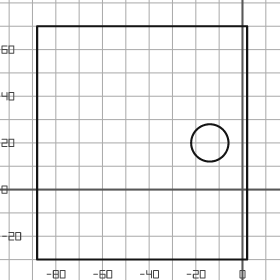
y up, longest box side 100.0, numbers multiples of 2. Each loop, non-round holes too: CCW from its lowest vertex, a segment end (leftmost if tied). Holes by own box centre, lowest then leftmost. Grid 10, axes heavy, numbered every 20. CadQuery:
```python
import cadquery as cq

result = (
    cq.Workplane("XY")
    .moveTo(-88.0, -30.0)
    .lineTo(2.0, -30.0)
    .lineTo(2.0, 70.0)
    .lineTo(-88.0, 70.0)
    .close()
    .moveTo(-14.0, 20.0)
    .circle(8.0)
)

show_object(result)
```